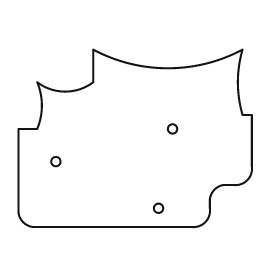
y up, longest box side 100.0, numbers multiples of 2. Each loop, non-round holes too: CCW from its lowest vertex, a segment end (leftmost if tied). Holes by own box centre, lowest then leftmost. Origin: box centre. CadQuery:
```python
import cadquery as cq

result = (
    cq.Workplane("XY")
    .moveTo(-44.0, -38.0)
    .lineTo(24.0, -38.0)
    .threePointArc((30.0, -36.0), (32.0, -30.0))
    .lineTo(32.0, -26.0)
    .threePointArc((34.0, -22.0), (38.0, -20.0))
    .lineTo(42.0, -20.0)
    .threePointArc((48.0, -18.0), (50.0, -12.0))
    .lineTo(50.0, 10.0)
    .lineTo(46.0, 10.0)
    .threePointArc((44.0, 24.0), (46.0, 38.0))
    .threePointArc((14.0, 30.0), (-18.0, 38.0))
    .lineTo(-18.0, 24.0)
    .threePointArc((-30.0, 20.0), (-42.0, 24.0))
    .threePointArc((-40.0, 14.0), (-42.0, 4.0))
    .lineTo(-50.0, 4.0)
    .lineTo(-50.0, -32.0)
    .threePointArc((-48.0, -36.0), (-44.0, -38.0))
    .close()
    .moveTo(10.0, -30.0)
    .circle(2.0)
    .moveTo(-34.0, -10.0)
    .circle(2.0)
    .moveTo(16.0, 4.0)
    .circle(2.0)
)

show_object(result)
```